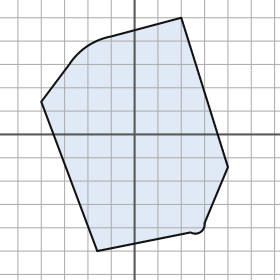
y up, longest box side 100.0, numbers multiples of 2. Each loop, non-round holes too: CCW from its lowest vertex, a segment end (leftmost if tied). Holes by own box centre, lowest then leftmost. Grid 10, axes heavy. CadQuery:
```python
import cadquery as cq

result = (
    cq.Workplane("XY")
    .moveTo(-16.0, -50.0)
    .lineTo(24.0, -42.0)
    .threePointArc((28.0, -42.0), (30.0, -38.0))
    .lineTo(40.0, -14.0)
    .lineTo(20.0, 50.0)
    .lineTo(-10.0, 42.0)
    .threePointArc((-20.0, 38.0), (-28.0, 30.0))
    .lineTo(-40.0, 14.0)
    .close()
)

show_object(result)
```